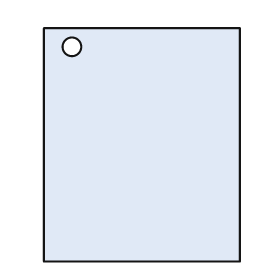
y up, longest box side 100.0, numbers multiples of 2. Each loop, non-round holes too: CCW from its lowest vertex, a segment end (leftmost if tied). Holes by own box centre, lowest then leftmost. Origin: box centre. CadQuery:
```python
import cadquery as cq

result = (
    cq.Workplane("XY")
    .moveTo(-42.0, -50.0)
    .lineTo(42.0, -50.0)
    .lineTo(42.0, 50.0)
    .lineTo(-42.0, 50.0)
    .close()
    .moveTo(-30.0, 42.0)
    .circle(4.0)
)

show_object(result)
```